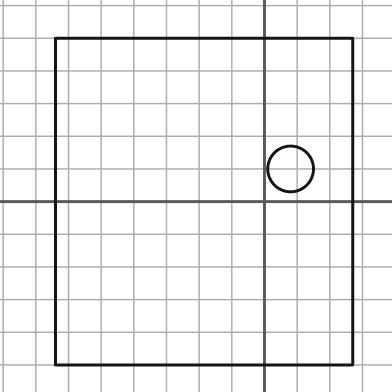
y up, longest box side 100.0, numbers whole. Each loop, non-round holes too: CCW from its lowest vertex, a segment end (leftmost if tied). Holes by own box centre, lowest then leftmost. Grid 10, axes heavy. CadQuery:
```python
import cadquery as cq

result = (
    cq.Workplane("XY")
    .moveTo(-64.0, -50.0)
    .lineTo(27.0, -50.0)
    .lineTo(27.0, 50.0)
    .lineTo(-64.0, 50.0)
    .close()
    .moveTo(8.0, 10.0)
    .circle(7.0)
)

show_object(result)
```